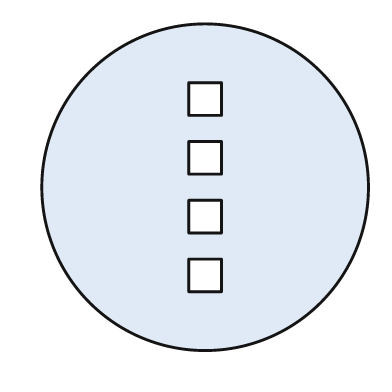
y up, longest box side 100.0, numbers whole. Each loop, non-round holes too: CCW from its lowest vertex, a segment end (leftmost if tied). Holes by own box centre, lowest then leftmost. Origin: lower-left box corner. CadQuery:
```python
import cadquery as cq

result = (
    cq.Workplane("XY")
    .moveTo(50.0, 50.0)
    .circle(50.0)
    .moveTo(45.0, 18.0)
    .lineTo(55.0, 18.0)
    .lineTo(55.0, 28.0)
    .lineTo(45.0, 28.0)
    .close()
    .moveTo(45.0, 36.0)
    .lineTo(55.0, 36.0)
    .lineTo(55.0, 46.0)
    .lineTo(45.0, 46.0)
    .close()
    .moveTo(45.0, 54.0)
    .lineTo(55.0, 54.0)
    .lineTo(55.0, 64.0)
    .lineTo(45.0, 64.0)
    .close()
    .moveTo(45.0, 72.0)
    .lineTo(55.0, 72.0)
    .lineTo(55.0, 82.0)
    .lineTo(45.0, 82.0)
    .close()
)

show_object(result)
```